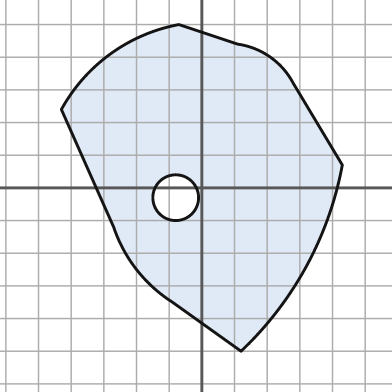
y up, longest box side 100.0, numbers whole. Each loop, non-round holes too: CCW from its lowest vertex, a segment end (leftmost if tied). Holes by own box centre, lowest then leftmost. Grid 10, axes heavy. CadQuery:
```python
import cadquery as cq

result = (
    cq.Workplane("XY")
    .moveTo(12.0, -50.0)
    .threePointArc((32.0, -24.0), (43.0, 7.0))
    .lineTo(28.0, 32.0)
    .threePointArc((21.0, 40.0), (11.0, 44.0))
    .lineTo(-7.0, 50.0)
    .threePointArc((-28.0, 41.0), (-43.0, 24.0))
    .lineTo(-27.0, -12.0)
    .threePointArc((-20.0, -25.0), (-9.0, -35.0))
    .close()
    .moveTo(-8.0, -3.0)
    .circle(7.0)
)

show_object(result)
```